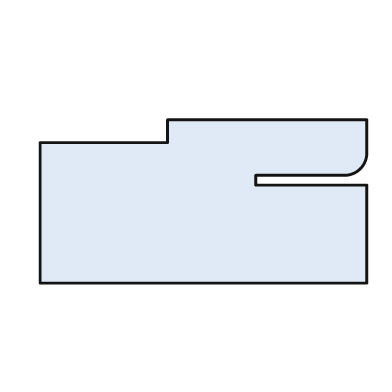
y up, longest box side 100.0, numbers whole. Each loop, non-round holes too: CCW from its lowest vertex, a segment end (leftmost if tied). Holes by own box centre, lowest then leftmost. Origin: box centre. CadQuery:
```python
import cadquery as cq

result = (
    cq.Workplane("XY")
    .moveTo(-50.0, -25.0)
    .lineTo(50.0, -25.0)
    .lineTo(50.0, 5.0)
    .lineTo(16.0, 5.0)
    .lineTo(16.0, 8.0)
    .lineTo(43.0, 8.0)
    .threePointArc((48.0, 10.0), (50.0, 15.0))
    .lineTo(50.0, 25.0)
    .lineTo(-11.0, 25.0)
    .lineTo(-11.0, 18.0)
    .lineTo(-50.0, 18.0)
    .close()
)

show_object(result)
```